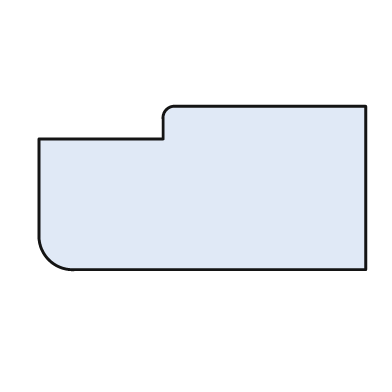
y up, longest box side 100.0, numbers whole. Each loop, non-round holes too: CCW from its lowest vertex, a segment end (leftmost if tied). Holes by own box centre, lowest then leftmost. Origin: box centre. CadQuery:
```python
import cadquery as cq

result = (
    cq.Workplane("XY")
    .moveTo(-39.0, -25.0)
    .lineTo(50.0, -25.0)
    .lineTo(50.0, 25.0)
    .lineTo(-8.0, 25.0)
    .threePointArc((-11.0, 24.0), (-12.0, 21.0))
    .lineTo(-12.0, 15.0)
    .lineTo(-50.0, 15.0)
    .lineTo(-50.0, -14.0)
    .threePointArc((-47.0, -22.0), (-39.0, -25.0))
    .close()
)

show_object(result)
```